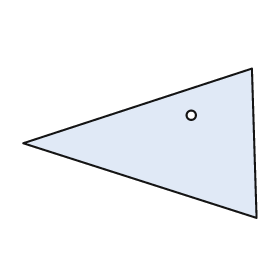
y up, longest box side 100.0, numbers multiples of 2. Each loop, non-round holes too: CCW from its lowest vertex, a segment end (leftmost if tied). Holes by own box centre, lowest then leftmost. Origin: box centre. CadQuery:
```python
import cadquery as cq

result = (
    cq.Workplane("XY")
    .moveTo(50.0, -32.0)
    .lineTo(48.0, 32.0)
    .lineTo(-50.0, 0.0)
    .close()
    .moveTo(22.0, 12.0)
    .circle(2.0)
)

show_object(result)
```